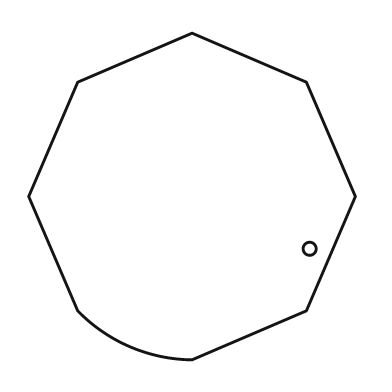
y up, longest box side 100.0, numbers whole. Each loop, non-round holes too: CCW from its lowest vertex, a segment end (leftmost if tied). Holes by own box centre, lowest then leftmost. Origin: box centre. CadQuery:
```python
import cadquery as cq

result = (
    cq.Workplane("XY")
    .moveTo(0.0, -50.0)
    .lineTo(35.0, -35.0)
    .lineTo(50.0, 0.0)
    .lineTo(35.0, 35.0)
    .lineTo(0.0, 50.0)
    .lineTo(-35.0, 35.0)
    .lineTo(-50.0, 0.0)
    .lineTo(-35.0, -35.0)
    .threePointArc((-19.0, -46.0), (0.0, -50.0))
    .close()
    .moveTo(36.0, -16.0)
    .circle(2.0)
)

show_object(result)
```